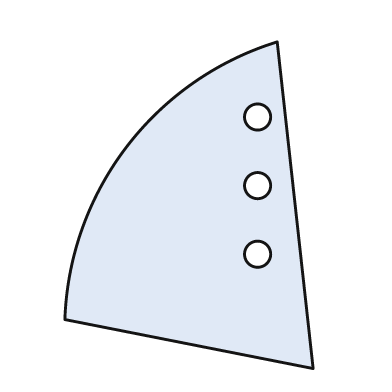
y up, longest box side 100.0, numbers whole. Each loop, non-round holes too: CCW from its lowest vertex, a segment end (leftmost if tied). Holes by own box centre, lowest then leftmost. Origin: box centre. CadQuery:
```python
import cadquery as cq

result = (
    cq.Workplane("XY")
    .moveTo(38.0, -50.0)
    .lineTo(27.0, 50.0)
    .threePointArc((-19.0, 18.0), (-38.0, -35.0))
    .close()
    .moveTo(21.0, -15.0)
    .circle(4.0)
    .moveTo(21.0, 6.0)
    .circle(4.0)
    .moveTo(21.0, 27.0)
    .circle(4.0)
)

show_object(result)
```